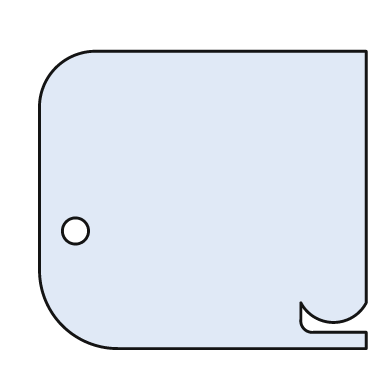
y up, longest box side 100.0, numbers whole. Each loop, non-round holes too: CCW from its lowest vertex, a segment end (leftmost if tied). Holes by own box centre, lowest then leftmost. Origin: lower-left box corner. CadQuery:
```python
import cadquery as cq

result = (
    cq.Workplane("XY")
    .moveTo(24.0, 0.0)
    .lineTo(100.0, 0.0)
    .lineTo(100.0, 5.0)
    .lineTo(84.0, 5.0)
    .threePointArc((81.0, 6.0), (80.0, 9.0))
    .lineTo(80.0, 14.0)
    .threePointArc((90.0, 8.0), (100.0, 14.0))
    .lineTo(100.0, 91.0)
    .lineTo(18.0, 91.0)
    .threePointArc((5.0, 86.0), (0.0, 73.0))
    .lineTo(0.0, 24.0)
    .threePointArc((7.0, 7.0), (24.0, 0.0))
    .close()
    .moveTo(11.0, 36.0)
    .circle(4.0)
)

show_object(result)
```